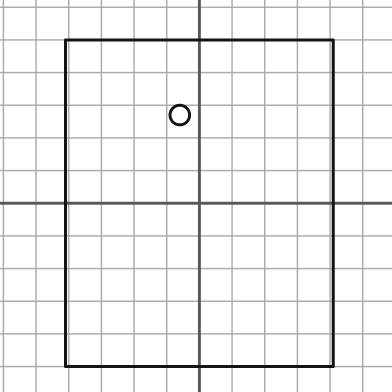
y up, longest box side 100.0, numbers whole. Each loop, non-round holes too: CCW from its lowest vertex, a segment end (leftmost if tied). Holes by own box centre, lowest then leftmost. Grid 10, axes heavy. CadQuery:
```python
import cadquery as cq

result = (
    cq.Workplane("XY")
    .moveTo(-41.0, -50.0)
    .lineTo(41.0, -50.0)
    .lineTo(41.0, 50.0)
    .lineTo(-41.0, 50.0)
    .close()
    .moveTo(-6.0, 27.0)
    .circle(3.0)
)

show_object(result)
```